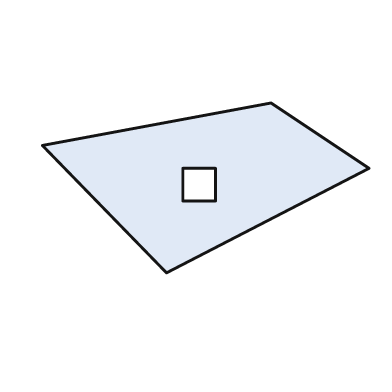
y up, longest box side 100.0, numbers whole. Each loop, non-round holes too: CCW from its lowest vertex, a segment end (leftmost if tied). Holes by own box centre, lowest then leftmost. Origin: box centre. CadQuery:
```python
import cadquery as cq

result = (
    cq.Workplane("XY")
    .moveTo(-12.0, -26.0)
    .lineTo(50.0, 6.0)
    .lineTo(20.0, 26.0)
    .lineTo(-50.0, 13.0)
    .close()
    .moveTo(-7.0, -4.0)
    .lineTo(3.0, -4.0)
    .lineTo(3.0, 6.0)
    .lineTo(-7.0, 6.0)
    .close()
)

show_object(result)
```